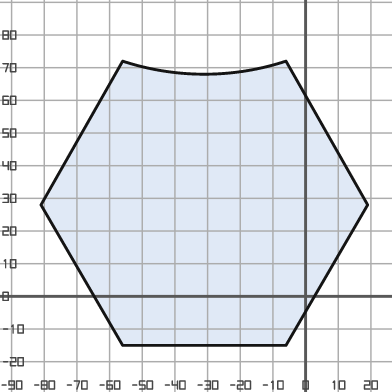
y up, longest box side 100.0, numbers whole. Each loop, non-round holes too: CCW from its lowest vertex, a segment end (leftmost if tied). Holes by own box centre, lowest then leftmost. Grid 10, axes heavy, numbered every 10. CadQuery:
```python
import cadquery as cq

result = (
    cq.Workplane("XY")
    .moveTo(-56.0, -15.0)
    .lineTo(-6.0, -15.0)
    .lineTo(19.0, 28.0)
    .lineTo(-6.0, 72.0)
    .threePointArc((-31.0, 68.0), (-56.0, 72.0))
    .lineTo(-81.0, 28.0)
    .close()
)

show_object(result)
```